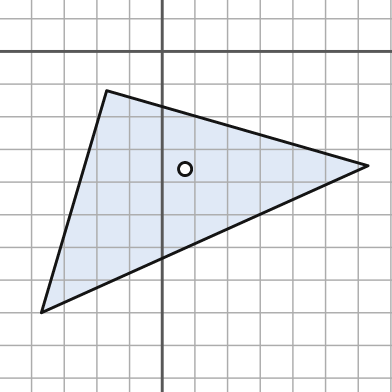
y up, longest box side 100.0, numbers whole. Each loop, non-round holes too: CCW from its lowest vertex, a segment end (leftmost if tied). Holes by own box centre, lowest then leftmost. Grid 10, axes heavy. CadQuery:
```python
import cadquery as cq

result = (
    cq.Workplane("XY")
    .moveTo(-37.0, -80.0)
    .lineTo(63.0, -35.0)
    .lineTo(-17.0, -12.0)
    .close()
    .moveTo(7.0, -36.0)
    .circle(2.0)
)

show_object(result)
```